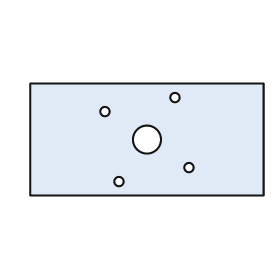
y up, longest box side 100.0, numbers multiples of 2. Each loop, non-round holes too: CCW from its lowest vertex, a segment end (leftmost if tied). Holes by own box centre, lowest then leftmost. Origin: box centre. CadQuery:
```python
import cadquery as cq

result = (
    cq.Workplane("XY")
    .moveTo(-50.0, -24.0)
    .lineTo(50.0, -24.0)
    .lineTo(50.0, 24.0)
    .lineTo(-50.0, 24.0)
    .close()
    .moveTo(-12.0, -18.0)
    .circle(2.0)
    .moveTo(18.0, -12.0)
    .circle(2.0)
    .moveTo(0.0, 0.0)
    .circle(6.0)
    .moveTo(-18.0, 12.0)
    .circle(2.0)
    .moveTo(12.0, 18.0)
    .circle(2.0)
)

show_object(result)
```